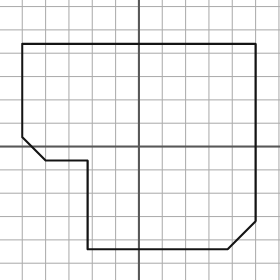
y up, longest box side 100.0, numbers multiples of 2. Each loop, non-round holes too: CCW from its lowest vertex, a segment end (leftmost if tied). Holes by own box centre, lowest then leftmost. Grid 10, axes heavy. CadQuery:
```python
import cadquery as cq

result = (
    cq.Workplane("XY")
    .moveTo(-22.0, -44.0)
    .lineTo(38.0, -44.0)
    .lineTo(50.0, -32.0)
    .lineTo(50.0, 44.0)
    .lineTo(-50.0, 44.0)
    .lineTo(-50.0, 4.0)
    .lineTo(-40.0, -6.0)
    .lineTo(-22.0, -6.0)
    .close()
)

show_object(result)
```